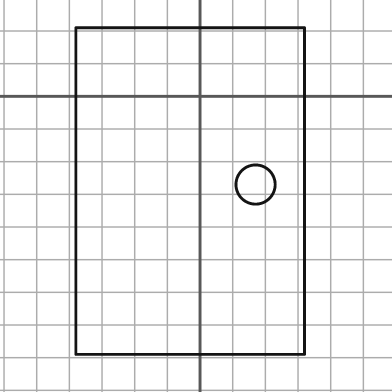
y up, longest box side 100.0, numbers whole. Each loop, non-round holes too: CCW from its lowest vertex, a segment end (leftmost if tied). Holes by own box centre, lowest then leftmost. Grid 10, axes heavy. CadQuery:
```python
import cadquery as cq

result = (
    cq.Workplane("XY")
    .moveTo(-38.0, -79.0)
    .lineTo(32.0, -79.0)
    .lineTo(32.0, 21.0)
    .lineTo(-38.0, 21.0)
    .close()
    .moveTo(17.0, -27.0)
    .circle(6.0)
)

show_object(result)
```